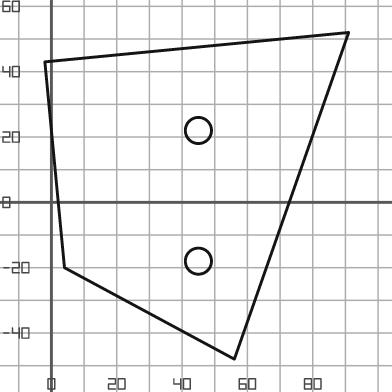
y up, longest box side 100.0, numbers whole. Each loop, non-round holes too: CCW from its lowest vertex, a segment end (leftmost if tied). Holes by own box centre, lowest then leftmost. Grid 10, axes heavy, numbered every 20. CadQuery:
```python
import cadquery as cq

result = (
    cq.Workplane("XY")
    .moveTo(56.0, -48.0)
    .lineTo(91.0, 52.0)
    .lineTo(-2.0, 43.0)
    .lineTo(4.0, -20.0)
    .close()
    .moveTo(45.0, -18.0)
    .circle(4.0)
    .moveTo(45.0, 22.0)
    .circle(4.0)
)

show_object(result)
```